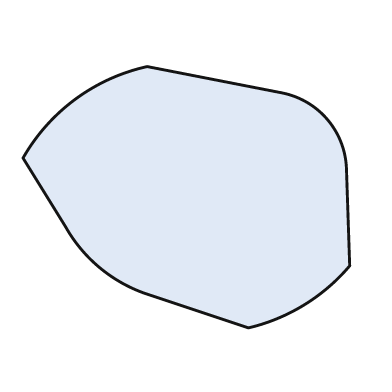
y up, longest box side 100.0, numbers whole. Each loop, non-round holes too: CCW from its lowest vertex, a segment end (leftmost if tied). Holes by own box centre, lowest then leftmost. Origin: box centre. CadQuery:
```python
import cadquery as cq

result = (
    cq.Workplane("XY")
    .moveTo(19.0, -40.0)
    .threePointArc((36.0, -33.0), (50.0, -21.0))
    .lineTo(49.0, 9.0)
    .threePointArc((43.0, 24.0), (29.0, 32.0))
    .lineTo(-12.0, 40.0)
    .threePointArc((-34.0, 30.0), (-50.0, 12.0))
    .lineTo(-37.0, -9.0)
    .threePointArc((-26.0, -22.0), (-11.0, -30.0))
    .close()
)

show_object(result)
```